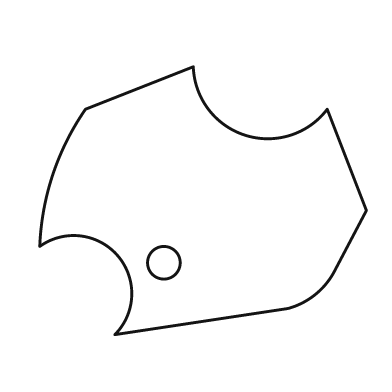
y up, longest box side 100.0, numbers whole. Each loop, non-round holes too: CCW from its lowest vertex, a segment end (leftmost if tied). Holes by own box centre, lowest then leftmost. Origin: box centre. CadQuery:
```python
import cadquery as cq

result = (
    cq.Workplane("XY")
    .moveTo(-27.0, -41.0)
    .lineTo(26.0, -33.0)
    .threePointArc((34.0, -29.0), (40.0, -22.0))
    .lineTo(50.0, -3.0)
    .lineTo(38.0, 28.0)
    .threePointArc((13.0, 20.0), (-3.0, 41.0))
    .lineTo(-36.0, 28.0)
    .threePointArc((-46.0, 8.0), (-50.0, -14.0))
    .threePointArc((-26.0, -17.0), (-27.0, -41.0))
    .close()
    .moveTo(-12.0, -19.0)
    .circle(5.0)
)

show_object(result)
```